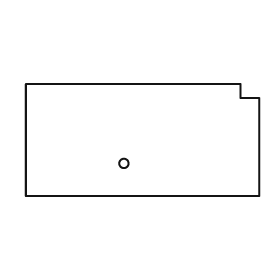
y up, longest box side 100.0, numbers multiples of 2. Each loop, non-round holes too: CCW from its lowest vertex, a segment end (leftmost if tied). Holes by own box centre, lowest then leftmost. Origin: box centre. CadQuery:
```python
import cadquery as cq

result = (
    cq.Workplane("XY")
    .moveTo(-50.0, -24.0)
    .lineTo(50.0, -24.0)
    .lineTo(50.0, 18.0)
    .lineTo(42.0, 18.0)
    .lineTo(42.0, 24.0)
    .lineTo(-50.0, 24.0)
    .close()
    .moveTo(-8.0, -10.0)
    .circle(2.0)
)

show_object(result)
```